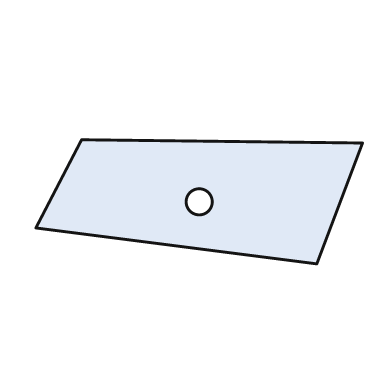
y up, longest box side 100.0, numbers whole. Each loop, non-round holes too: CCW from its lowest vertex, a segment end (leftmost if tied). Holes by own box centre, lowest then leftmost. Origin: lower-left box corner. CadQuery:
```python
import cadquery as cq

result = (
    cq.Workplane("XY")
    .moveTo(86.0, 0.0)
    .lineTo(100.0, 37.0)
    .lineTo(14.0, 38.0)
    .lineTo(0.0, 11.0)
    .close()
    .moveTo(50.0, 19.0)
    .circle(4.0)
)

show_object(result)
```